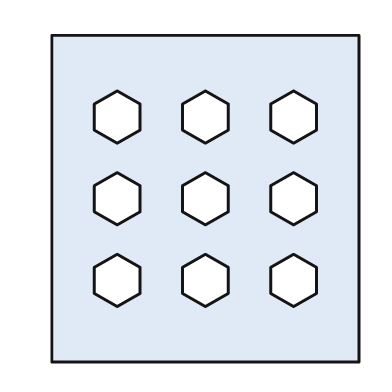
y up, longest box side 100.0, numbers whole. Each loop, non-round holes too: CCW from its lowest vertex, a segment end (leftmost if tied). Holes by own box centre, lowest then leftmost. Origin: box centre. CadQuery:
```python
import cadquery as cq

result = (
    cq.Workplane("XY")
    .moveTo(-47.0, -50.0)
    .lineTo(47.0, -50.0)
    .lineTo(47.0, 50.0)
    .lineTo(-47.0, 50.0)
    .close()
    .moveTo(-27.0, -33.0)
    .lineTo(-20.0, -29.0)
    .lineTo(-20.0, -21.0)
    .lineTo(-27.0, -17.0)
    .lineTo(-34.0, -21.0)
    .lineTo(-34.0, -29.0)
    .close()
    .moveTo(0.0, -33.0)
    .lineTo(7.0, -29.0)
    .lineTo(7.0, -21.0)
    .lineTo(0.0, -17.0)
    .lineTo(-7.0, -21.0)
    .lineTo(-7.0, -29.0)
    .close()
    .moveTo(27.0, -33.0)
    .lineTo(34.0, -29.0)
    .lineTo(34.0, -21.0)
    .lineTo(27.0, -17.0)
    .lineTo(20.0, -21.0)
    .lineTo(20.0, -29.0)
    .close()
    .moveTo(-27.0, -8.0)
    .lineTo(-20.0, -4.0)
    .lineTo(-20.0, 4.0)
    .lineTo(-27.0, 8.0)
    .lineTo(-34.0, 4.0)
    .lineTo(-34.0, -4.0)
    .close()
    .moveTo(0.0, -8.0)
    .lineTo(7.0, -4.0)
    .lineTo(7.0, 4.0)
    .lineTo(0.0, 8.0)
    .lineTo(-7.0, 4.0)
    .lineTo(-7.0, -4.0)
    .close()
    .moveTo(27.0, -8.0)
    .lineTo(34.0, -4.0)
    .lineTo(34.0, 4.0)
    .lineTo(27.0, 8.0)
    .lineTo(20.0, 4.0)
    .lineTo(20.0, -4.0)
    .close()
    .moveTo(-27.0, 17.0)
    .lineTo(-20.0, 21.0)
    .lineTo(-20.0, 29.0)
    .lineTo(-27.0, 33.0)
    .lineTo(-34.0, 29.0)
    .lineTo(-34.0, 21.0)
    .close()
    .moveTo(0.0, 17.0)
    .lineTo(7.0, 21.0)
    .lineTo(7.0, 29.0)
    .lineTo(0.0, 33.0)
    .lineTo(-7.0, 29.0)
    .lineTo(-7.0, 21.0)
    .close()
    .moveTo(27.0, 17.0)
    .lineTo(34.0, 21.0)
    .lineTo(34.0, 29.0)
    .lineTo(27.0, 33.0)
    .lineTo(20.0, 29.0)
    .lineTo(20.0, 21.0)
    .close()
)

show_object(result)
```